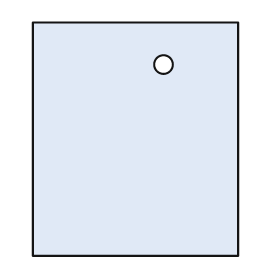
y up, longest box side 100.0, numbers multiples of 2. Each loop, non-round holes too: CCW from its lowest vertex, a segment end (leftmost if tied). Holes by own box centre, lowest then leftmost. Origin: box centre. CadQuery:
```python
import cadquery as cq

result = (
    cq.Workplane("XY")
    .moveTo(-44.0, -50.0)
    .lineTo(44.0, -50.0)
    .lineTo(44.0, 50.0)
    .lineTo(-44.0, 50.0)
    .close()
    .moveTo(12.0, 32.0)
    .circle(4.0)
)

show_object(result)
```